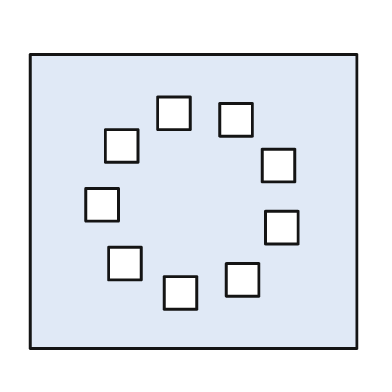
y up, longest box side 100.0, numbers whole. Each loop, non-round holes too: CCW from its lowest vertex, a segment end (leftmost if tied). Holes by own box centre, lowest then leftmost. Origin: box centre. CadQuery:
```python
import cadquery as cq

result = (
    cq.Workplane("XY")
    .moveTo(-50.0, -45.0)
    .lineTo(50.0, -45.0)
    .lineTo(50.0, 45.0)
    .lineTo(-50.0, 45.0)
    .close()
    .moveTo(-9.0, -33.0)
    .lineTo(1.0, -33.0)
    .lineTo(1.0, -23.0)
    .lineTo(-9.0, -23.0)
    .close()
    .moveTo(10.0, -29.0)
    .lineTo(20.0, -29.0)
    .lineTo(20.0, -19.0)
    .lineTo(10.0, -19.0)
    .close()
    .moveTo(-26.0, -24.0)
    .lineTo(-16.0, -24.0)
    .lineTo(-16.0, -14.0)
    .lineTo(-26.0, -14.0)
    .close()
    .moveTo(22.0, -13.0)
    .lineTo(32.0, -13.0)
    .lineTo(32.0, -3.0)
    .lineTo(22.0, -3.0)
    .close()
    .moveTo(-33.0, -6.0)
    .lineTo(-23.0, -6.0)
    .lineTo(-23.0, 4.0)
    .lineTo(-33.0, 4.0)
    .close()
    .moveTo(21.0, 6.0)
    .lineTo(31.0, 6.0)
    .lineTo(31.0, 16.0)
    .lineTo(21.0, 16.0)
    .close()
    .moveTo(-27.0, 12.0)
    .lineTo(-17.0, 12.0)
    .lineTo(-17.0, 22.0)
    .lineTo(-27.0, 22.0)
    .close()
    .moveTo(8.0, 20.0)
    .lineTo(18.0, 20.0)
    .lineTo(18.0, 30.0)
    .lineTo(8.0, 30.0)
    .close()
    .moveTo(-11.0, 22.0)
    .lineTo(-1.0, 22.0)
    .lineTo(-1.0, 32.0)
    .lineTo(-11.0, 32.0)
    .close()
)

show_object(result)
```